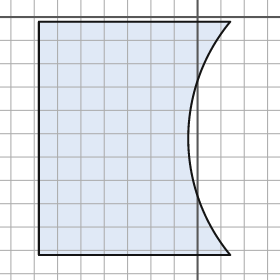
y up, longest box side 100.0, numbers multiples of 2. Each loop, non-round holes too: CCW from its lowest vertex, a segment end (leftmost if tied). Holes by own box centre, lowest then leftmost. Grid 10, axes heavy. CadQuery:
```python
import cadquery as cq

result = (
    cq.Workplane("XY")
    .moveTo(-68.0, -102.0)
    .lineTo(14.0, -102.0)
    .threePointArc((-4.0, -52.0), (14.0, -2.0))
    .lineTo(-68.0, -2.0)
    .close()
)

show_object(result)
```